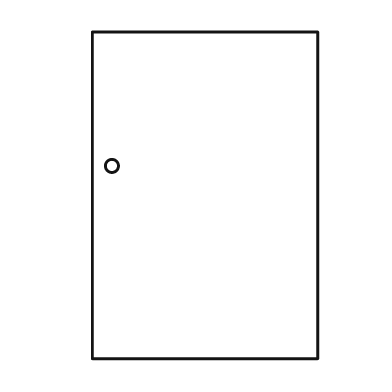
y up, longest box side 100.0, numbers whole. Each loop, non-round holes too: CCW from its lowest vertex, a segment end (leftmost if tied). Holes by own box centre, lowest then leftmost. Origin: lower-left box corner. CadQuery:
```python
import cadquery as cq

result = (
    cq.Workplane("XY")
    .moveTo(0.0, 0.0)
    .lineTo(69.0, 0.0)
    .lineTo(69.0, 100.0)
    .lineTo(0.0, 100.0)
    .close()
    .moveTo(6.0, 59.0)
    .circle(2.0)
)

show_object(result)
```